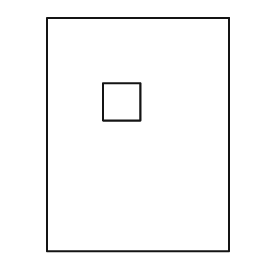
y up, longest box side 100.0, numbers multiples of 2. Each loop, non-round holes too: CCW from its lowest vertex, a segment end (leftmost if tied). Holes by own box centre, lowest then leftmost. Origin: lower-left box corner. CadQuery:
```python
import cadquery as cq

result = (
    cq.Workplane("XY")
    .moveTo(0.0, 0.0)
    .lineTo(78.0, 0.0)
    .lineTo(78.0, 100.0)
    .lineTo(0.0, 100.0)
    .close()
    .moveTo(24.0, 56.0)
    .lineTo(40.0, 56.0)
    .lineTo(40.0, 72.0)
    .lineTo(24.0, 72.0)
    .close()
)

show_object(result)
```